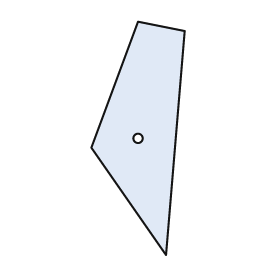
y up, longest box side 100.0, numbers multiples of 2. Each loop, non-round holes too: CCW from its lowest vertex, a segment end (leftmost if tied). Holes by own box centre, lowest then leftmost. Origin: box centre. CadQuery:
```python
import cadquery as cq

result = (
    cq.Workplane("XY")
    .moveTo(12.0, -50.0)
    .lineTo(20.0, 46.0)
    .lineTo(0.0, 50.0)
    .lineTo(-20.0, -4.0)
    .close()
    .moveTo(0.0, 0.0)
    .circle(2.0)
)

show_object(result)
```